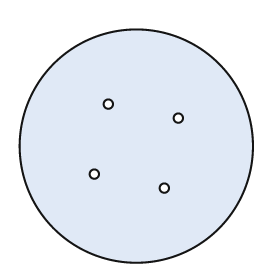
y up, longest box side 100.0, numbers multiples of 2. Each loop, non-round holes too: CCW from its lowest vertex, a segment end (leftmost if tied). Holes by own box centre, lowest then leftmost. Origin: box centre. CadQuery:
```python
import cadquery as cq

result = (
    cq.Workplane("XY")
    .moveTo(0.0, 0.0)
    .circle(50.0)
    .moveTo(12.0, -18.0)
    .circle(2.0)
    .moveTo(-18.0, -12.0)
    .circle(2.0)
    .moveTo(18.0, 12.0)
    .circle(2.0)
    .moveTo(-12.0, 18.0)
    .circle(2.0)
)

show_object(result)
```